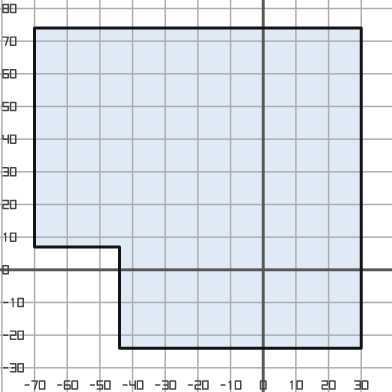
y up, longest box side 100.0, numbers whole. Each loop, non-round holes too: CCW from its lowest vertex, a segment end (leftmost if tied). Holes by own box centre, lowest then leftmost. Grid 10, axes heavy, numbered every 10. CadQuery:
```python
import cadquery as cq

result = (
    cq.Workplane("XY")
    .moveTo(-44.0, -24.0)
    .lineTo(30.0, -24.0)
    .lineTo(30.0, 74.0)
    .lineTo(-70.0, 74.0)
    .lineTo(-70.0, 7.0)
    .lineTo(-44.0, 7.0)
    .close()
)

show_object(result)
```